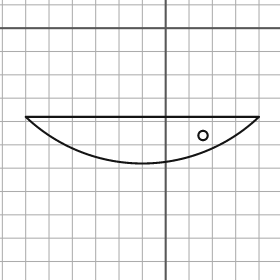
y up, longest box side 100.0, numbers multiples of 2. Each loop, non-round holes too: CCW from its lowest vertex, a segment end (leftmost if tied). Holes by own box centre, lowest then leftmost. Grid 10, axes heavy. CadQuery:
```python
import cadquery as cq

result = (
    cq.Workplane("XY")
    .moveTo(-60.0, -38.0)
    .threePointArc((-10.0, -58.0), (40.0, -38.0))
    .close()
    .moveTo(16.0, -46.0)
    .circle(2.0)
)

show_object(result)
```